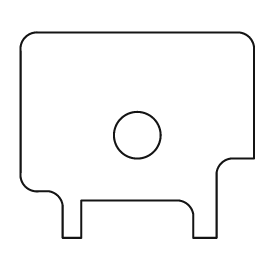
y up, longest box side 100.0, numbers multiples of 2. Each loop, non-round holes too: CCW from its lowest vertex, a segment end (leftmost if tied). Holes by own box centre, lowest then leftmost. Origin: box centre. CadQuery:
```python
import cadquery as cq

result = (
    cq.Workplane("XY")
    .moveTo(-32.0, -44.0)
    .lineTo(-24.0, -44.0)
    .lineTo(-24.0, -28.0)
    .lineTo(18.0, -28.0)
    .threePointArc((22.0, -30.0), (24.0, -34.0))
    .lineTo(24.0, -44.0)
    .lineTo(34.0, -44.0)
    .lineTo(34.0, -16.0)
    .threePointArc((36.0, -12.0), (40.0, -10.0))
    .lineTo(50.0, -10.0)
    .lineTo(50.0, 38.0)
    .threePointArc((48.0, 42.0), (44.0, 44.0))
    .lineTo(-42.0, 44.0)
    .threePointArc((-48.0, 42.0), (-50.0, 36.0))
    .lineTo(-50.0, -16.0)
    .threePointArc((-48.0, -22.0), (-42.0, -24.0))
    .lineTo(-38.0, -24.0)
    .threePointArc((-34.0, -26.0), (-32.0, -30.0))
    .close()
    .moveTo(0.0, 0.0)
    .circle(10.0)
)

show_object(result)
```